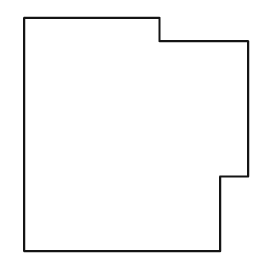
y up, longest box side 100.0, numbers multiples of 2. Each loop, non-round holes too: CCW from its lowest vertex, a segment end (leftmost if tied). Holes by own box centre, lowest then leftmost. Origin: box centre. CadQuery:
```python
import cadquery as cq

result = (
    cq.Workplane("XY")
    .moveTo(-48.0, -50.0)
    .lineTo(36.0, -50.0)
    .lineTo(36.0, -18.0)
    .lineTo(48.0, -18.0)
    .lineTo(48.0, 40.0)
    .lineTo(10.0, 40.0)
    .lineTo(10.0, 50.0)
    .lineTo(-48.0, 50.0)
    .close()
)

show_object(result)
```